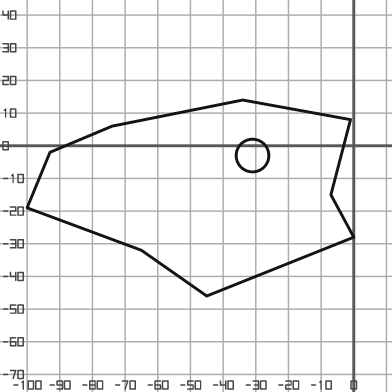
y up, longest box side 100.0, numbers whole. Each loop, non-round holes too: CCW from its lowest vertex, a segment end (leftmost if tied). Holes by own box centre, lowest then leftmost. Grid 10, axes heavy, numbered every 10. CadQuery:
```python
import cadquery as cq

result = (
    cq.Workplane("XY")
    .moveTo(-45.0, -46.0)
    .lineTo(0.0, -28.0)
    .lineTo(-7.0, -15.0)
    .lineTo(-1.0, 8.0)
    .lineTo(-34.0, 14.0)
    .lineTo(-74.0, 6.0)
    .lineTo(-93.0, -2.0)
    .lineTo(-100.0, -19.0)
    .lineTo(-65.0, -32.0)
    .close()
    .moveTo(-31.0, -3.0)
    .circle(5.0)
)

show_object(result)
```